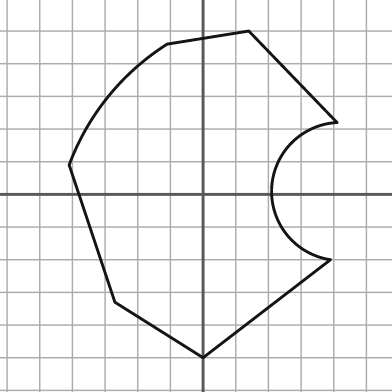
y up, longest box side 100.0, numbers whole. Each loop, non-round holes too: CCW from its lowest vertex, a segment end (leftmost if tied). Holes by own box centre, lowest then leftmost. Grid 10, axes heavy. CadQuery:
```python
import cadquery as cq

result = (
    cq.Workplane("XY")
    .moveTo(0.0, -50.0)
    .lineTo(39.0, -20.0)
    .threePointArc((21.0, 2.0), (41.0, 22.0))
    .lineTo(14.0, 50.0)
    .lineTo(-11.0, 46.0)
    .threePointArc((-29.0, 30.0), (-41.0, 9.0))
    .lineTo(-27.0, -33.0)
    .close()
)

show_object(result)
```